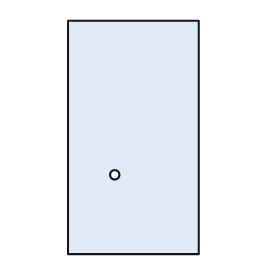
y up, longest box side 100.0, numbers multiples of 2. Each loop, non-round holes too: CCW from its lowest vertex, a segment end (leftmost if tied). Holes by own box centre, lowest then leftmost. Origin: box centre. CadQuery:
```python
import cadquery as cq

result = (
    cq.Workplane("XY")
    .moveTo(-28.0, -50.0)
    .lineTo(28.0, -50.0)
    .lineTo(28.0, 50.0)
    .lineTo(-28.0, 50.0)
    .close()
    .moveTo(-8.0, -16.0)
    .circle(2.0)
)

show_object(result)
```